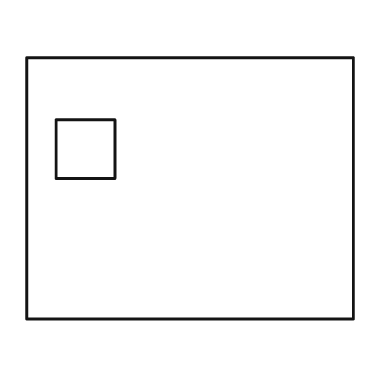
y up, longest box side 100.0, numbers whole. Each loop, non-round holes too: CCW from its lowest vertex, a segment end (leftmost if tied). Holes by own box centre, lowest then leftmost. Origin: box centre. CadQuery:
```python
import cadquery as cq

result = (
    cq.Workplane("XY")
    .moveTo(-50.0, -40.0)
    .lineTo(50.0, -40.0)
    .lineTo(50.0, 40.0)
    .lineTo(-50.0, 40.0)
    .close()
    .moveTo(-41.0, 3.0)
    .lineTo(-23.0, 3.0)
    .lineTo(-23.0, 21.0)
    .lineTo(-41.0, 21.0)
    .close()
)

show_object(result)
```